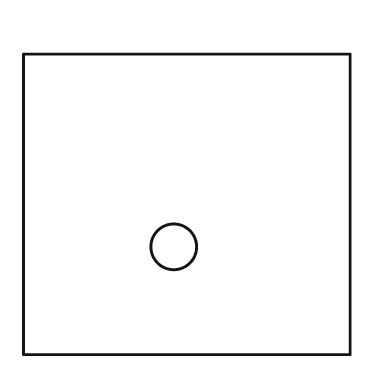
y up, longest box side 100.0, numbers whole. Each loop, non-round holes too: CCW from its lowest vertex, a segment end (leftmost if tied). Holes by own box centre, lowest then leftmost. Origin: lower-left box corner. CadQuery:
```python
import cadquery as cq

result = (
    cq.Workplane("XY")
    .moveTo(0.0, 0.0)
    .lineTo(100.0, 0.0)
    .lineTo(100.0, 92.0)
    .lineTo(0.0, 92.0)
    .close()
    .moveTo(46.0, 33.0)
    .circle(7.0)
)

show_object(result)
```